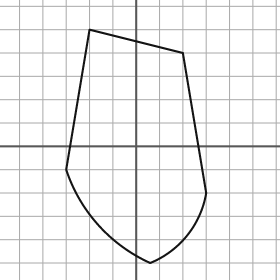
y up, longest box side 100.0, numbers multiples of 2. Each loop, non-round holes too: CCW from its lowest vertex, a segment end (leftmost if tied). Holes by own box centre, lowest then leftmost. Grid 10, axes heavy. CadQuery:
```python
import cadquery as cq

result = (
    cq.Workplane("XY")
    .moveTo(6.0, -50.0)
    .threePointArc((22.0, -38.0), (30.0, -20.0))
    .lineTo(20.0, 40.0)
    .lineTo(-20.0, 50.0)
    .lineTo(-30.0, -10.0)
    .threePointArc((-16.0, -34.0), (6.0, -50.0))
    .close()
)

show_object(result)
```